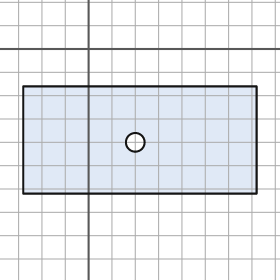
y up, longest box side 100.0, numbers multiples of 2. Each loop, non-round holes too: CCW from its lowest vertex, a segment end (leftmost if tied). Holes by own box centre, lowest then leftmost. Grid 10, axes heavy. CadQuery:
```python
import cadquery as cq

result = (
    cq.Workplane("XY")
    .moveTo(-28.0, -62.0)
    .lineTo(72.0, -62.0)
    .lineTo(72.0, -16.0)
    .lineTo(-28.0, -16.0)
    .close()
    .moveTo(20.0, -40.0)
    .circle(4.0)
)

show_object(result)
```